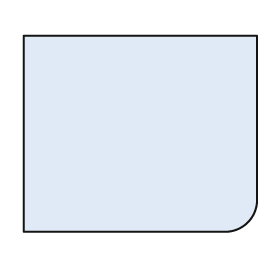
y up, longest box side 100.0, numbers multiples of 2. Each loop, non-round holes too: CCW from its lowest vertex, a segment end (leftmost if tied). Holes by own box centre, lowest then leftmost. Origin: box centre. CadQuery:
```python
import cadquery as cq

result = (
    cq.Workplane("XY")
    .moveTo(-50.0, -42.0)
    .lineTo(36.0, -42.0)
    .threePointArc((46.0, -38.0), (50.0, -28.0))
    .lineTo(50.0, 42.0)
    .lineTo(-50.0, 42.0)
    .close()
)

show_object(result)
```